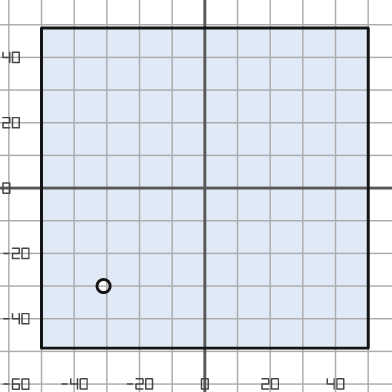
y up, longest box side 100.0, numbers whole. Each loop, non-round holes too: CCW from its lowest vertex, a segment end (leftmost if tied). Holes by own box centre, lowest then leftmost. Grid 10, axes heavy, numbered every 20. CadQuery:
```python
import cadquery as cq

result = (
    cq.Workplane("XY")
    .moveTo(-50.0, -49.0)
    .lineTo(50.0, -49.0)
    .lineTo(50.0, 49.0)
    .lineTo(-50.0, 49.0)
    .close()
    .moveTo(-31.0, -30.0)
    .circle(2.0)
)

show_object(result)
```